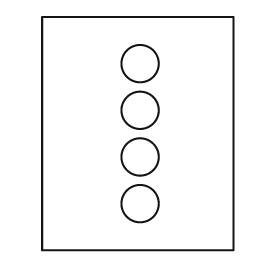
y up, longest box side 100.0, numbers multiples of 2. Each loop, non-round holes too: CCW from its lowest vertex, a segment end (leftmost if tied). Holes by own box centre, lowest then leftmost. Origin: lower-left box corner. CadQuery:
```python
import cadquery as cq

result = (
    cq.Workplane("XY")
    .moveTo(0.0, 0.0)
    .lineTo(82.0, 0.0)
    .lineTo(82.0, 100.0)
    .lineTo(0.0, 100.0)
    .close()
    .moveTo(42.0, 20.0)
    .circle(8.0)
    .moveTo(42.0, 40.0)
    .circle(8.0)
    .moveTo(42.0, 60.0)
    .circle(8.0)
    .moveTo(42.0, 80.0)
    .circle(8.0)
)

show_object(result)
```